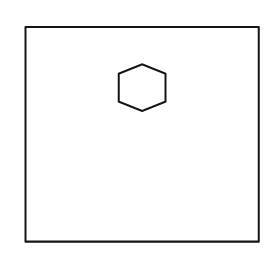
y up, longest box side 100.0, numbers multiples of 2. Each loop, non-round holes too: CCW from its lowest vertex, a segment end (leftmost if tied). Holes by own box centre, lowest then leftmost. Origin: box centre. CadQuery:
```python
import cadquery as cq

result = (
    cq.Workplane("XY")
    .moveTo(-50.0, -46.0)
    .lineTo(50.0, -46.0)
    .lineTo(50.0, 46.0)
    .lineTo(-50.0, 46.0)
    .close()
    .moveTo(0.0, 10.0)
    .lineTo(10.0, 14.0)
    .lineTo(10.0, 26.0)
    .lineTo(0.0, 30.0)
    .lineTo(-10.0, 26.0)
    .lineTo(-10.0, 14.0)
    .close()
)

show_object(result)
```